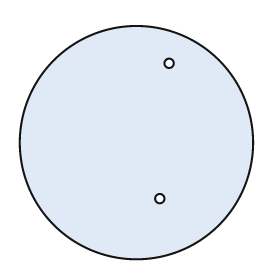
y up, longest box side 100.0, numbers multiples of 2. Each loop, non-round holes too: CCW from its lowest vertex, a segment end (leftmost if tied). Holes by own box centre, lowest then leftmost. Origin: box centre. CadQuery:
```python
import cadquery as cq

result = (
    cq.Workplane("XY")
    .moveTo(0.0, 0.0)
    .circle(50.0)
    .moveTo(10.0, -24.0)
    .circle(2.0)
    .moveTo(14.0, 34.0)
    .circle(2.0)
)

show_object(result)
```